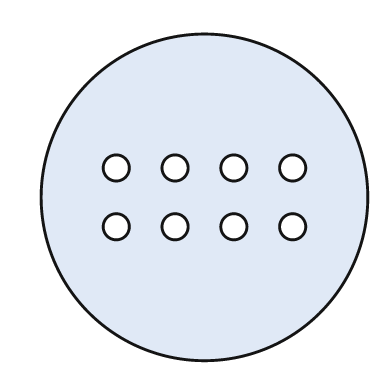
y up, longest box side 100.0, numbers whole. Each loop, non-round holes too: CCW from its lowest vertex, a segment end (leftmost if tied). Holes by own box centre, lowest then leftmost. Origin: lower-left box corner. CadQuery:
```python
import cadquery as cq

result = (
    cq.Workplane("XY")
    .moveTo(50.0, 50.0)
    .circle(50.0)
    .moveTo(23.0, 41.0)
    .circle(4.0)
    .moveTo(41.0, 41.0)
    .circle(4.0)
    .moveTo(59.0, 41.0)
    .circle(4.0)
    .moveTo(77.0, 41.0)
    .circle(4.0)
    .moveTo(23.0, 59.0)
    .circle(4.0)
    .moveTo(41.0, 59.0)
    .circle(4.0)
    .moveTo(59.0, 59.0)
    .circle(4.0)
    .moveTo(77.0, 59.0)
    .circle(4.0)
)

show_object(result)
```